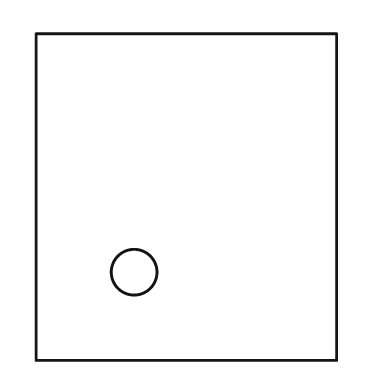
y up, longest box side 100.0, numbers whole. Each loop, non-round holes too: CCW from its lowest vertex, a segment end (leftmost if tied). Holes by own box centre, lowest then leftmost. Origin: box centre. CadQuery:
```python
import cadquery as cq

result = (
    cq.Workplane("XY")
    .moveTo(-46.0, -50.0)
    .lineTo(46.0, -50.0)
    .lineTo(46.0, 50.0)
    .lineTo(-46.0, 50.0)
    .close()
    .moveTo(-16.0, -23.0)
    .circle(7.0)
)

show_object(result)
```